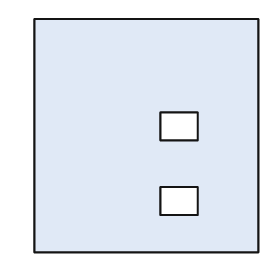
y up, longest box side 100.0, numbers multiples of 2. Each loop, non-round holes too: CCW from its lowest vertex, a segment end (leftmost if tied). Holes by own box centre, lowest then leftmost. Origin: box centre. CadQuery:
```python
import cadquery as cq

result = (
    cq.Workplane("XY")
    .moveTo(-48.0, -50.0)
    .lineTo(48.0, -50.0)
    .lineTo(48.0, 50.0)
    .lineTo(-48.0, 50.0)
    .close()
    .moveTo(6.0, -34.0)
    .lineTo(22.0, -34.0)
    .lineTo(22.0, -22.0)
    .lineTo(6.0, -22.0)
    .close()
    .moveTo(6.0, -2.0)
    .lineTo(22.0, -2.0)
    .lineTo(22.0, 10.0)
    .lineTo(6.0, 10.0)
    .close()
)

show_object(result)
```